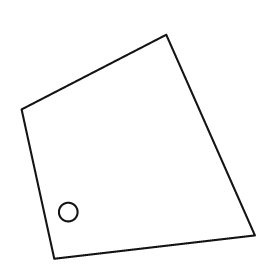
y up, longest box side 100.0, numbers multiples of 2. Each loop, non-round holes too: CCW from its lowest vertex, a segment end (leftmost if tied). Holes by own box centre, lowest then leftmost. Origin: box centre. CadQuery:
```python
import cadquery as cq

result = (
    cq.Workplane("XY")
    .moveTo(-36.0, -48.0)
    .lineTo(50.0, -38.0)
    .lineTo(12.0, 48.0)
    .lineTo(-50.0, 16.0)
    .close()
    .moveTo(-30.0, -28.0)
    .circle(4.0)
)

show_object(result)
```